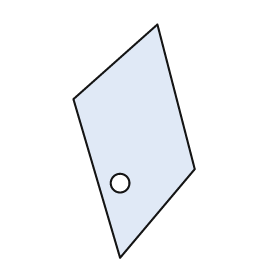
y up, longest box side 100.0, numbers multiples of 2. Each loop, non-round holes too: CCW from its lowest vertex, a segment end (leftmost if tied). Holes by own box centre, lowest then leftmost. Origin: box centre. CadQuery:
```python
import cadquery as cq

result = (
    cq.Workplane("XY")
    .moveTo(-6.0, -50.0)
    .lineTo(26.0, -12.0)
    .lineTo(10.0, 50.0)
    .lineTo(-26.0, 18.0)
    .close()
    .moveTo(-6.0, -18.0)
    .circle(4.0)
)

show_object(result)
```